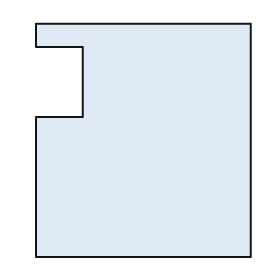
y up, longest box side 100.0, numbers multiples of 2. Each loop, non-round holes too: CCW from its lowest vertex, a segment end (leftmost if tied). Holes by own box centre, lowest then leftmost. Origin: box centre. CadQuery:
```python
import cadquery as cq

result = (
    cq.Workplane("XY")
    .moveTo(-46.0, -50.0)
    .lineTo(46.0, -50.0)
    .lineTo(46.0, 50.0)
    .lineTo(-46.0, 50.0)
    .lineTo(-46.0, 40.0)
    .lineTo(-26.0, 40.0)
    .lineTo(-26.0, 10.0)
    .lineTo(-46.0, 10.0)
    .close()
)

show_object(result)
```